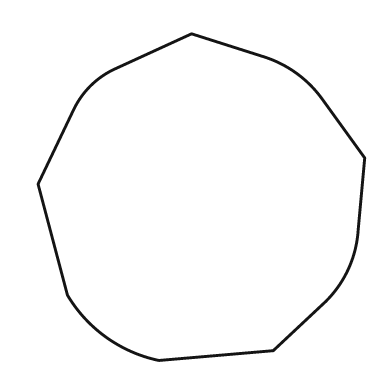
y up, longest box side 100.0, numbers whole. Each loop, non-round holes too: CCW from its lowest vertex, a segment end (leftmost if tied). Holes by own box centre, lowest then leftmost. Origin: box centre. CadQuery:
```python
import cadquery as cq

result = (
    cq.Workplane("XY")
    .moveTo(-13.0, -50.0)
    .lineTo(22.0, -47.0)
    .lineTo(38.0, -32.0)
    .threePointArc((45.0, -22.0), (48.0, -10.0))
    .lineTo(50.0, 12.0)
    .lineTo(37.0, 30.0)
    .threePointArc((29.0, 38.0), (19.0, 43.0))
    .lineTo(-3.0, 50.0)
    .lineTo(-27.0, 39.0)
    .threePointArc((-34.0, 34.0), (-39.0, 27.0))
    .lineTo(-50.0, 4.0)
    .lineTo(-41.0, -30.0)
    .threePointArc((-29.0, -43.0), (-13.0, -50.0))
    .close()
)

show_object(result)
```